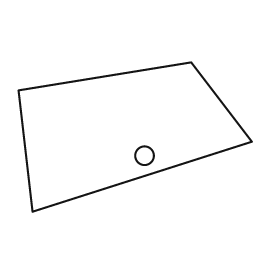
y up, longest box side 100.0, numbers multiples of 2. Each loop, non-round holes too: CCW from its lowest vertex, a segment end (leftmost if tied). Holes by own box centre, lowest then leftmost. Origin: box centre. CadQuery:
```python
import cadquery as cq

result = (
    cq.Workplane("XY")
    .moveTo(-44.0, -32.0)
    .lineTo(50.0, -2.0)
    .lineTo(24.0, 32.0)
    .lineTo(-50.0, 20.0)
    .close()
    .moveTo(4.0, -8.0)
    .circle(4.0)
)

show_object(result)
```